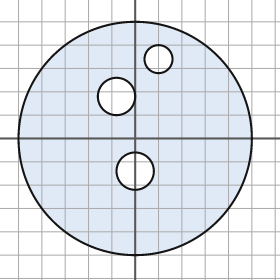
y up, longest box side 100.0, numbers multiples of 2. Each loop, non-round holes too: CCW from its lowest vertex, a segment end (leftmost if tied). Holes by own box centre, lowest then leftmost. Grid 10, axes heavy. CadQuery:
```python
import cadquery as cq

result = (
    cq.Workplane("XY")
    .moveTo(0.0, 0.0)
    .circle(50.0)
    .moveTo(0.0, -14.0)
    .circle(8.0)
    .moveTo(-8.0, 18.0)
    .circle(8.0)
    .moveTo(10.0, 34.0)
    .circle(6.0)
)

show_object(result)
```